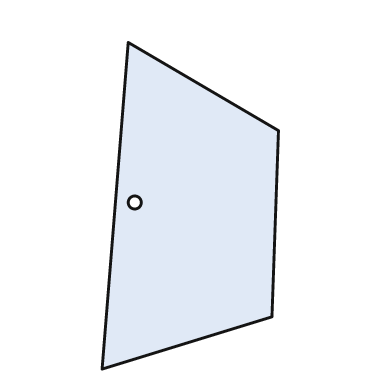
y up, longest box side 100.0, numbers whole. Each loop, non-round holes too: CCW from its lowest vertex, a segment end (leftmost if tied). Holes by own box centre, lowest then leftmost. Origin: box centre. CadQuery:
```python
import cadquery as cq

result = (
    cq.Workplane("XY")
    .moveTo(-27.0, -50.0)
    .lineTo(25.0, -34.0)
    .lineTo(27.0, 23.0)
    .lineTo(-19.0, 50.0)
    .close()
    .moveTo(-17.0, 1.0)
    .circle(2.0)
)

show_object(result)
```